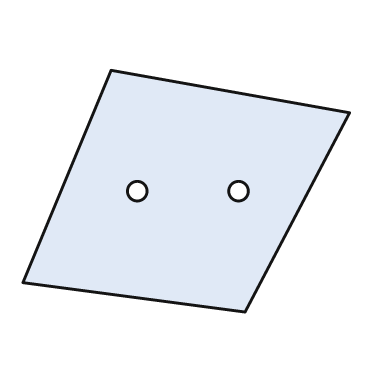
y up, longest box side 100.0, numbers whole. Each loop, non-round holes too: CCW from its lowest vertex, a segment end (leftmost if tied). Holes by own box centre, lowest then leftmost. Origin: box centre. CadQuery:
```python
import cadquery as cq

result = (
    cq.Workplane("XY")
    .moveTo(18.0, -37.0)
    .lineTo(50.0, 24.0)
    .lineTo(-23.0, 37.0)
    .lineTo(-50.0, -28.0)
    .close()
    .moveTo(-15.0, 0.0)
    .circle(3.0)
    .moveTo(16.0, 0.0)
    .circle(3.0)
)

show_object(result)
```